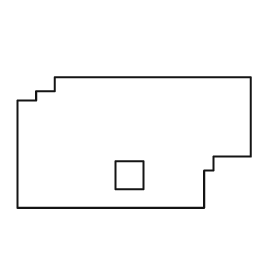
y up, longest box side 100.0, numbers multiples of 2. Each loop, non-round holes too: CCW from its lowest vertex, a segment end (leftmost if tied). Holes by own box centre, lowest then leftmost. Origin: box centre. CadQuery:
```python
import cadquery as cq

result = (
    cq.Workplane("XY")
    .moveTo(-50.0, -28.0)
    .lineTo(30.0, -28.0)
    .lineTo(30.0, -12.0)
    .lineTo(34.0, -12.0)
    .lineTo(34.0, -6.0)
    .lineTo(50.0, -6.0)
    .lineTo(50.0, 28.0)
    .lineTo(-34.0, 28.0)
    .lineTo(-34.0, 22.0)
    .lineTo(-42.0, 22.0)
    .lineTo(-42.0, 18.0)
    .lineTo(-50.0, 18.0)
    .close()
    .moveTo(-8.0, -20.0)
    .lineTo(4.0, -20.0)
    .lineTo(4.0, -8.0)
    .lineTo(-8.0, -8.0)
    .close()
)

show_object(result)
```